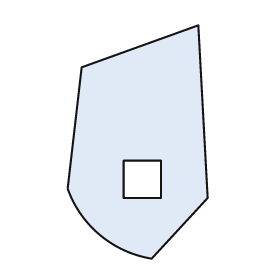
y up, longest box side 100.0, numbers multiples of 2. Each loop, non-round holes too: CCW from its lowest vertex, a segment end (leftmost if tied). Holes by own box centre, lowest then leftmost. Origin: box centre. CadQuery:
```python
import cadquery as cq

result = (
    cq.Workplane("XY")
    .moveTo(6.0, -50.0)
    .lineTo(30.0, -24.0)
    .lineTo(26.0, 50.0)
    .lineTo(-24.0, 32.0)
    .lineTo(-30.0, -20.0)
    .threePointArc((-16.0, -40.0), (6.0, -50.0))
    .close()
    .moveTo(-6.0, -24.0)
    .lineTo(10.0, -24.0)
    .lineTo(10.0, -8.0)
    .lineTo(-6.0, -8.0)
    .close()
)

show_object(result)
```